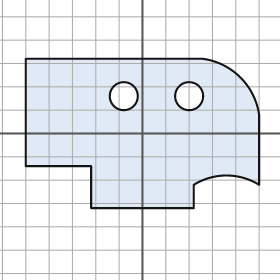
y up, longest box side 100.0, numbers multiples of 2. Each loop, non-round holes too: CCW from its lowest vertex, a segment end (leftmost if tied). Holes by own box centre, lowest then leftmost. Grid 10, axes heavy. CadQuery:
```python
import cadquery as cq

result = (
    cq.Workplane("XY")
    .moveTo(-22.0, -32.0)
    .lineTo(22.0, -32.0)
    .lineTo(22.0, -22.0)
    .threePointArc((36.0, -18.0), (50.0, -22.0))
    .lineTo(50.0, 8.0)
    .threePointArc((42.0, 24.0), (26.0, 32.0))
    .lineTo(-50.0, 32.0)
    .lineTo(-50.0, -14.0)
    .lineTo(-22.0, -14.0)
    .close()
    .moveTo(-8.0, 16.0)
    .circle(6.0)
    .moveTo(20.0, 16.0)
    .circle(6.0)
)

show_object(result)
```